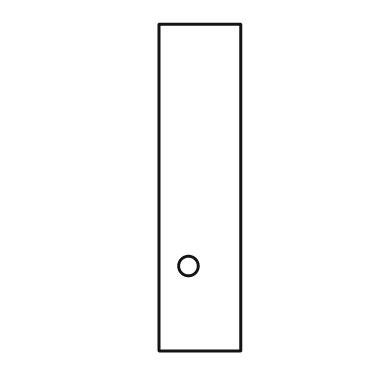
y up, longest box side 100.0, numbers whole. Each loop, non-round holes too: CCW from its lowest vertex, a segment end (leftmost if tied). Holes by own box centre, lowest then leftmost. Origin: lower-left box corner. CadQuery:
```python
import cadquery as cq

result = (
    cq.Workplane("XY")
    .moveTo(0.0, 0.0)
    .lineTo(25.0, 0.0)
    .lineTo(25.0, 100.0)
    .lineTo(0.0, 100.0)
    .close()
    .moveTo(9.0, 26.0)
    .circle(3.0)
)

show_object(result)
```